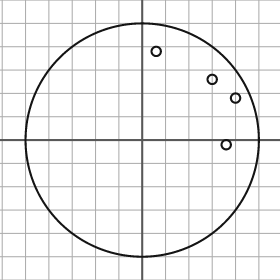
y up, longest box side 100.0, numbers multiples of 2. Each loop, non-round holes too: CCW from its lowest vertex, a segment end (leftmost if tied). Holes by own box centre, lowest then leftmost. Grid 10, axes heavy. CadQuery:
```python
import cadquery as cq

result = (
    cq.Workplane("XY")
    .moveTo(0.0, 0.0)
    .circle(50.0)
    .moveTo(36.0, -2.0)
    .circle(2.0)
    .moveTo(40.0, 18.0)
    .circle(2.0)
    .moveTo(30.0, 26.0)
    .circle(2.0)
    .moveTo(6.0, 38.0)
    .circle(2.0)
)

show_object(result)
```